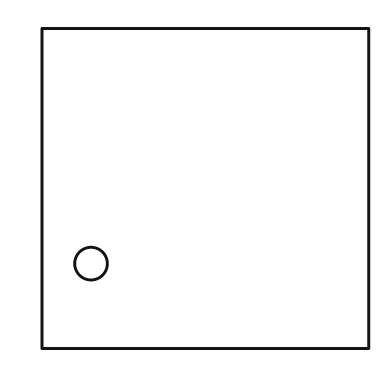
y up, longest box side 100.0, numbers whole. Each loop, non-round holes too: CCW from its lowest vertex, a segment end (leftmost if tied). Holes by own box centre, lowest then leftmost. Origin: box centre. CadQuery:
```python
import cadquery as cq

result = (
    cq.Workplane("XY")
    .moveTo(-50.0, -49.0)
    .lineTo(50.0, -49.0)
    .lineTo(50.0, 49.0)
    .lineTo(-50.0, 49.0)
    .close()
    .moveTo(-35.0, -23.0)
    .circle(5.0)
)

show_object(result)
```